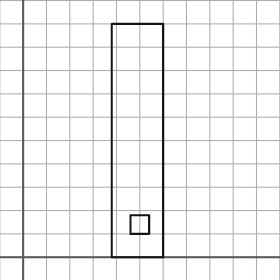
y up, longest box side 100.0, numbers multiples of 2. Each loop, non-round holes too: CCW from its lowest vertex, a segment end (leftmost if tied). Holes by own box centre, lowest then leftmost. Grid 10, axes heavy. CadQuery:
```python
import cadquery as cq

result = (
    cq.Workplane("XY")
    .moveTo(38.0, 0.0)
    .lineTo(60.0, 0.0)
    .lineTo(60.0, 100.0)
    .lineTo(38.0, 100.0)
    .close()
    .moveTo(46.0, 10.0)
    .lineTo(54.0, 10.0)
    .lineTo(54.0, 18.0)
    .lineTo(46.0, 18.0)
    .close()
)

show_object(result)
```